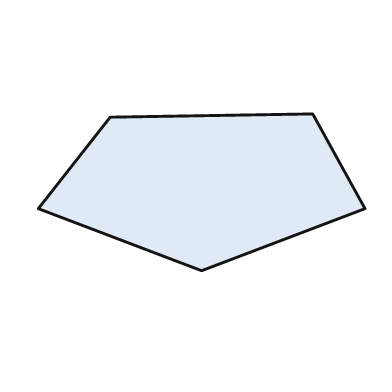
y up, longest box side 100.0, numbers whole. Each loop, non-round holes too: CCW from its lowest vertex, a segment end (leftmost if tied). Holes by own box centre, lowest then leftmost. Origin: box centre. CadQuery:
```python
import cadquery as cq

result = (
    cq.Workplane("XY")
    .moveTo(0.0, -24.0)
    .lineTo(50.0, -5.0)
    .lineTo(34.0, 24.0)
    .lineTo(-28.0, 23.0)
    .lineTo(-50.0, -5.0)
    .close()
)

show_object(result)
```